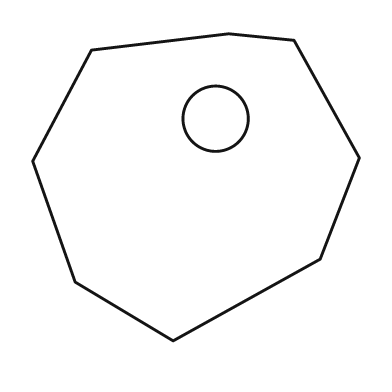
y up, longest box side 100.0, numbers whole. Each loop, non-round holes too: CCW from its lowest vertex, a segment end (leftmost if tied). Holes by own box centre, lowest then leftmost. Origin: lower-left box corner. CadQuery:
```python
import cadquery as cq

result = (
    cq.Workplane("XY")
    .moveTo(43.0, 0.0)
    .lineTo(88.0, 25.0)
    .lineTo(100.0, 56.0)
    .lineTo(80.0, 92.0)
    .lineTo(60.0, 94.0)
    .lineTo(18.0, 89.0)
    .lineTo(0.0, 55.0)
    .lineTo(13.0, 18.0)
    .close()
    .moveTo(56.0, 68.0)
    .circle(10.0)
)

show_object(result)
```